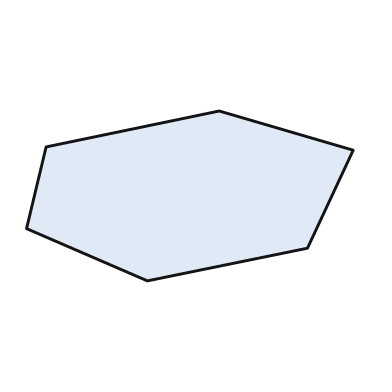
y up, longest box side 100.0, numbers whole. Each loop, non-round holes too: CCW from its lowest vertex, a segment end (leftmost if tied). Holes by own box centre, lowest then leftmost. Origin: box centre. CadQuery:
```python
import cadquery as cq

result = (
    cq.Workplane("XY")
    .moveTo(-13.0, -26.0)
    .lineTo(36.0, -16.0)
    .lineTo(50.0, 14.0)
    .lineTo(9.0, 26.0)
    .lineTo(-44.0, 15.0)
    .lineTo(-50.0, -10.0)
    .close()
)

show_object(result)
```